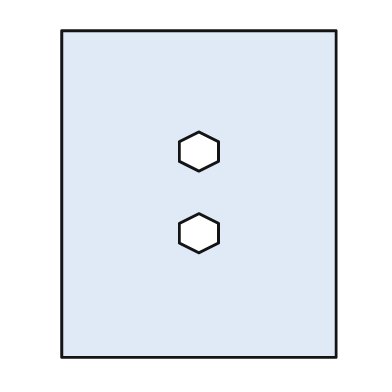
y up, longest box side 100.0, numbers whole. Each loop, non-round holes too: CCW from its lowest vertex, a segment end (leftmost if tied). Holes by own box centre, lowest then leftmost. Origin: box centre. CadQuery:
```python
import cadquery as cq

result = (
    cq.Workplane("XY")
    .moveTo(-42.0, -50.0)
    .lineTo(42.0, -50.0)
    .lineTo(42.0, 50.0)
    .lineTo(-42.0, 50.0)
    .close()
    .moveTo(0.0, -18.0)
    .lineTo(6.0, -15.0)
    .lineTo(6.0, -9.0)
    .lineTo(0.0, -6.0)
    .lineTo(-6.0, -9.0)
    .lineTo(-6.0, -15.0)
    .close()
    .moveTo(0.0, 7.0)
    .lineTo(6.0, 10.0)
    .lineTo(6.0, 16.0)
    .lineTo(0.0, 19.0)
    .lineTo(-6.0, 16.0)
    .lineTo(-6.0, 10.0)
    .close()
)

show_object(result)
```